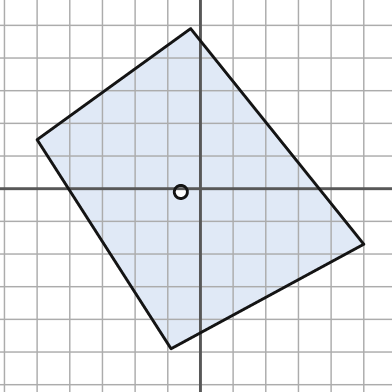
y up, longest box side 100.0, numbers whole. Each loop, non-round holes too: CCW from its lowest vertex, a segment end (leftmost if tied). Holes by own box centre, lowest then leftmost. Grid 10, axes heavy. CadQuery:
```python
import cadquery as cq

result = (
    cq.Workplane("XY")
    .moveTo(-9.0, -49.0)
    .lineTo(50.0, -17.0)
    .lineTo(-3.0, 49.0)
    .lineTo(-50.0, 15.0)
    .close()
    .moveTo(-6.0, -1.0)
    .circle(2.0)
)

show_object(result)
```